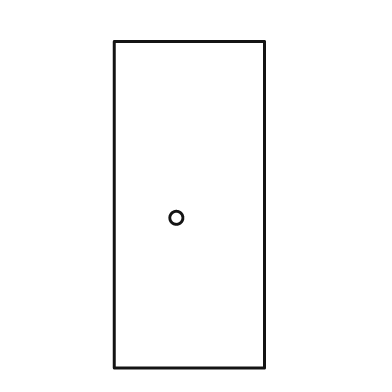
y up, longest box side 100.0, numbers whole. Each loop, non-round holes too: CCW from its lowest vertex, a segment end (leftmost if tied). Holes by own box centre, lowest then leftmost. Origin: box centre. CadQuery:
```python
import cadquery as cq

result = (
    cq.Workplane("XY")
    .moveTo(-23.0, -50.0)
    .lineTo(23.0, -50.0)
    .lineTo(23.0, 50.0)
    .lineTo(-23.0, 50.0)
    .close()
    .moveTo(-4.0, -4.0)
    .circle(2.0)
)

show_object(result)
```